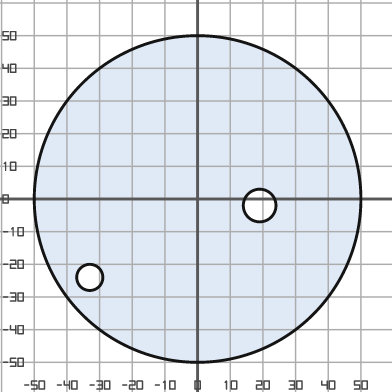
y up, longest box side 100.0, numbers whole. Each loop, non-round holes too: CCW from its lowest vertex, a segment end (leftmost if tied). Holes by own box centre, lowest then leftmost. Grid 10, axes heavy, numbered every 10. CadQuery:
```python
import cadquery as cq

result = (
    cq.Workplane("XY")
    .moveTo(0.0, 0.0)
    .circle(50.0)
    .moveTo(-33.0, -24.0)
    .circle(4.0)
    .moveTo(19.0, -2.0)
    .circle(5.0)
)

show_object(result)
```